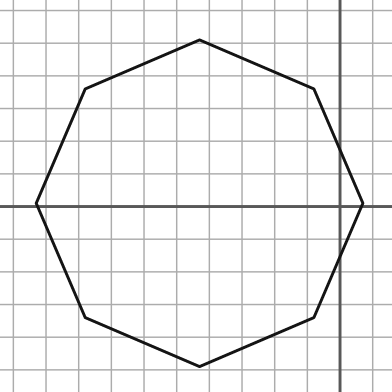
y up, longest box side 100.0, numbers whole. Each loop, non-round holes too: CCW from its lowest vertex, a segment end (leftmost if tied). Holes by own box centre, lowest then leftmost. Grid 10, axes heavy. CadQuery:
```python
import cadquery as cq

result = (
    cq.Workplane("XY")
    .moveTo(-43.0, -49.0)
    .lineTo(-8.0, -34.0)
    .lineTo(7.0, 1.0)
    .lineTo(-8.0, 36.0)
    .lineTo(-43.0, 51.0)
    .lineTo(-78.0, 36.0)
    .lineTo(-93.0, 1.0)
    .lineTo(-78.0, -34.0)
    .close()
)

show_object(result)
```